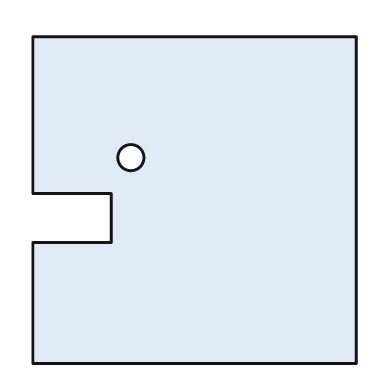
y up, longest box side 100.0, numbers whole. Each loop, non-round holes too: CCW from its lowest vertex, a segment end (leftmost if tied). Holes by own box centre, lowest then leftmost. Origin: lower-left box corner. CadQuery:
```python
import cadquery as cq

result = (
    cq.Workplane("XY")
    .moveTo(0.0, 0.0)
    .lineTo(99.0, 0.0)
    .lineTo(99.0, 100.0)
    .lineTo(0.0, 100.0)
    .lineTo(0.0, 52.0)
    .lineTo(24.0, 52.0)
    .lineTo(24.0, 37.0)
    .lineTo(0.0, 37.0)
    .close()
    .moveTo(30.0, 63.0)
    .circle(4.0)
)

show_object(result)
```